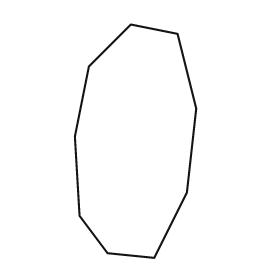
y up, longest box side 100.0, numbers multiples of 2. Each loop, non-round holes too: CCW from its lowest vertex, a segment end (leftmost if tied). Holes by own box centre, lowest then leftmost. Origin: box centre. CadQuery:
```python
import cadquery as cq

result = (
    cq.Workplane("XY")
    .moveTo(8.0, -50.0)
    .lineTo(22.0, -22.0)
    .lineTo(26.0, 14.0)
    .lineTo(18.0, 46.0)
    .lineTo(-2.0, 50.0)
    .lineTo(-20.0, 32.0)
    .lineTo(-26.0, 2.0)
    .lineTo(-24.0, -32.0)
    .lineTo(-12.0, -48.0)
    .close()
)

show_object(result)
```